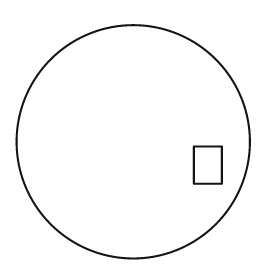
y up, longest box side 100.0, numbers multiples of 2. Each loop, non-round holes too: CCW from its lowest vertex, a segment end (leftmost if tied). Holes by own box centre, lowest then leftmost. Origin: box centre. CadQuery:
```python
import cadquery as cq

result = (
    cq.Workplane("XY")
    .moveTo(0.0, 0.0)
    .circle(50.0)
    .moveTo(26.0, -18.0)
    .lineTo(38.0, -18.0)
    .lineTo(38.0, -2.0)
    .lineTo(26.0, -2.0)
    .close()
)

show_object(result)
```